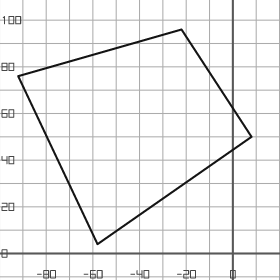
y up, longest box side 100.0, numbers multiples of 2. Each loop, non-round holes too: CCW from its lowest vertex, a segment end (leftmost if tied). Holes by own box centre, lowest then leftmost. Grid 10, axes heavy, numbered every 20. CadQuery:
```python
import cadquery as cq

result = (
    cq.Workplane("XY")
    .moveTo(-58.0, 4.0)
    .lineTo(8.0, 50.0)
    .lineTo(-22.0, 96.0)
    .lineTo(-92.0, 76.0)
    .close()
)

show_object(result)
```